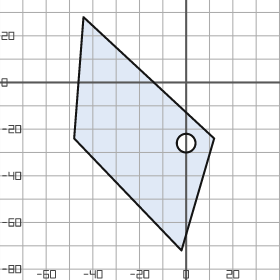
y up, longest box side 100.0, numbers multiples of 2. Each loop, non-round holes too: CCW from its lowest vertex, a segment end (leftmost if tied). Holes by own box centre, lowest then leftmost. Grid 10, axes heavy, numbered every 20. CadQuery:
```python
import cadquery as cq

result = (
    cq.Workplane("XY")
    .moveTo(-2.0, -72.0)
    .lineTo(12.0, -24.0)
    .lineTo(-44.0, 28.0)
    .lineTo(-48.0, -24.0)
    .close()
    .moveTo(0.0, -26.0)
    .circle(4.0)
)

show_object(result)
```